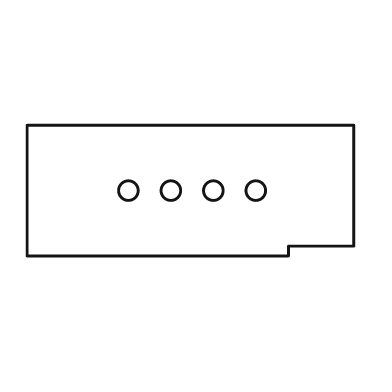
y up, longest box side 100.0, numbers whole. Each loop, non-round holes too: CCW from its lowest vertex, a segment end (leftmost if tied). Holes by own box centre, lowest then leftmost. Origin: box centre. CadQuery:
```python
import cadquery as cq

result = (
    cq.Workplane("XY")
    .moveTo(-50.0, -20.0)
    .lineTo(30.0, -20.0)
    .lineTo(30.0, -17.0)
    .lineTo(50.0, -17.0)
    .lineTo(50.0, 20.0)
    .lineTo(-50.0, 20.0)
    .close()
    .moveTo(-19.0, 0.0)
    .circle(3.0)
    .moveTo(-6.0, 0.0)
    .circle(3.0)
    .moveTo(7.0, 0.0)
    .circle(3.0)
    .moveTo(20.0, 0.0)
    .circle(3.0)
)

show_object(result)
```